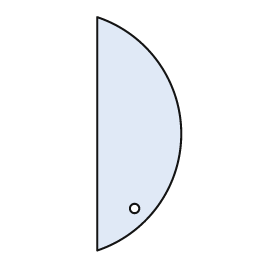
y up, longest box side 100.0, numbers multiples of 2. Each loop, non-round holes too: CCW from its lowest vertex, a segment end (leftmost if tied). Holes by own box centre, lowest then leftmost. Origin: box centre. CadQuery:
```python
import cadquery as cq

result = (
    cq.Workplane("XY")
    .moveTo(-18.0, -50.0)
    .threePointArc((18.0, 0.0), (-18.0, 50.0))
    .close()
    .moveTo(-2.0, -32.0)
    .circle(2.0)
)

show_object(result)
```